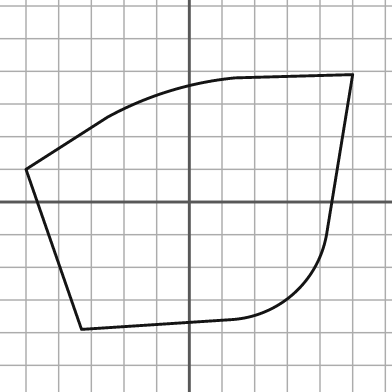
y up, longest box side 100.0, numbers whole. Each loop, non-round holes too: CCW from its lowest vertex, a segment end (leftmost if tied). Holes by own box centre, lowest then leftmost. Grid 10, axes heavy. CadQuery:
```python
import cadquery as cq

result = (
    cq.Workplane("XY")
    .moveTo(-33.0, -39.0)
    .lineTo(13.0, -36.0)
    .threePointArc((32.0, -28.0), (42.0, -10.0))
    .lineTo(50.0, 39.0)
    .lineTo(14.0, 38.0)
    .threePointArc((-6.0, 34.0), (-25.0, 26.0))
    .lineTo(-50.0, 10.0)
    .close()
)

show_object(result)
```